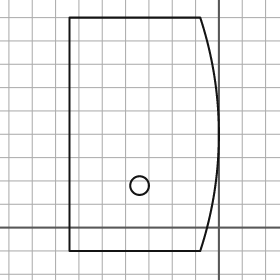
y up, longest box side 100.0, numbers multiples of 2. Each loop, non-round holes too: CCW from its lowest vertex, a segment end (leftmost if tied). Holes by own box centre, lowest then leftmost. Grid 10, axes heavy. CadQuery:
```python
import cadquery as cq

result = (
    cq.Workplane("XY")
    .moveTo(-64.0, -10.0)
    .lineTo(-8.0, -10.0)
    .threePointArc((0.0, 40.0), (-8.0, 90.0))
    .lineTo(-64.0, 90.0)
    .close()
    .moveTo(-34.0, 18.0)
    .circle(4.0)
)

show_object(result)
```